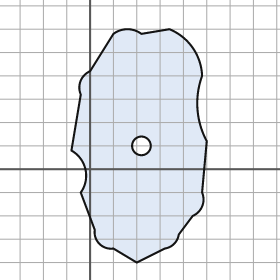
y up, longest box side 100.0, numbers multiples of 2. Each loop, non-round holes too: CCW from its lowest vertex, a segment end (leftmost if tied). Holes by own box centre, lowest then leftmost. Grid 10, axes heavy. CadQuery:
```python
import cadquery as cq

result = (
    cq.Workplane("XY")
    .moveTo(20.0, -40.0)
    .lineTo(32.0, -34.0)
    .threePointArc((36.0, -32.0), (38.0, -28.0))
    .lineTo(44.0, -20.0)
    .threePointArc((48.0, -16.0), (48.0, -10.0))
    .lineTo(50.0, 12.0)
    .threePointArc((46.0, 26.0), (48.0, 40.0))
    .threePointArc((44.0, 52.0), (34.0, 60.0))
    .lineTo(22.0, 58.0)
    .threePointArc((16.0, 60.0), (10.0, 58.0))
    .lineTo(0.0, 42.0)
    .threePointArc((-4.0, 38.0), (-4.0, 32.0))
    .lineTo(-8.0, 8.0)
    .threePointArc((-2.0, 0.0), (-4.0, -10.0))
    .lineTo(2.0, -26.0)
    .threePointArc((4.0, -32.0), (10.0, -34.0))
    .close()
    .moveTo(22.0, 10.0)
    .circle(4.0)
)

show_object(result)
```